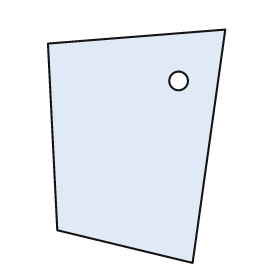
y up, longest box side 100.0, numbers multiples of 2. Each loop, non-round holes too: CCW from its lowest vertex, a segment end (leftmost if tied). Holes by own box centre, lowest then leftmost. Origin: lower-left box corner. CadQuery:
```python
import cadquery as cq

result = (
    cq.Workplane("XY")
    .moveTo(62.0, 0.0)
    .lineTo(76.0, 100.0)
    .lineTo(0.0, 94.0)
    .lineTo(4.0, 14.0)
    .close()
    .moveTo(56.0, 78.0)
    .circle(4.0)
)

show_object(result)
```